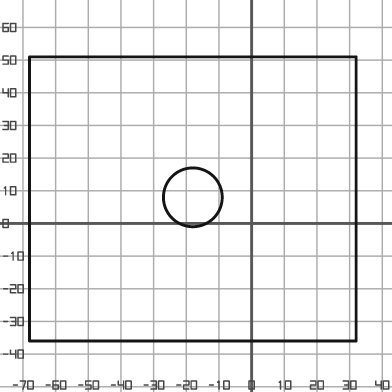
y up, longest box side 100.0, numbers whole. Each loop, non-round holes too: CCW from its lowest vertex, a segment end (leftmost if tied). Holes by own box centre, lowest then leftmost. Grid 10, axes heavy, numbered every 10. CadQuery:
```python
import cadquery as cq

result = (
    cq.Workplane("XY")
    .moveTo(-68.0, -36.0)
    .lineTo(32.0, -36.0)
    .lineTo(32.0, 51.0)
    .lineTo(-68.0, 51.0)
    .close()
    .moveTo(-18.0, 8.0)
    .circle(9.0)
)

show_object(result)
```